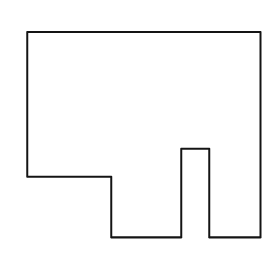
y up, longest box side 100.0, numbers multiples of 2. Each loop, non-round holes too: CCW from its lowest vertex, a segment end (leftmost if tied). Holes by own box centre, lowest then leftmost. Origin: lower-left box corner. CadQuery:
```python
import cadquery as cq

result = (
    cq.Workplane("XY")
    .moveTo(36.0, 0.0)
    .lineTo(66.0, 0.0)
    .lineTo(66.0, 38.0)
    .lineTo(78.0, 38.0)
    .lineTo(78.0, 0.0)
    .lineTo(100.0, 0.0)
    .lineTo(100.0, 88.0)
    .lineTo(0.0, 88.0)
    .lineTo(0.0, 26.0)
    .lineTo(36.0, 26.0)
    .close()
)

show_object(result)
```